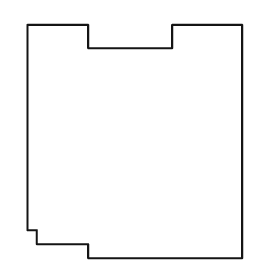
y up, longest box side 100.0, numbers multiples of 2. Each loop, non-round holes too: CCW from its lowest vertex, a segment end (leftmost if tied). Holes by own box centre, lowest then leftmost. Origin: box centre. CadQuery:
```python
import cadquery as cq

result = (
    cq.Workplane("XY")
    .moveTo(-20.0, -50.0)
    .lineTo(46.0, -50.0)
    .lineTo(46.0, 50.0)
    .lineTo(16.0, 50.0)
    .lineTo(16.0, 40.0)
    .lineTo(-20.0, 40.0)
    .lineTo(-20.0, 50.0)
    .lineTo(-46.0, 50.0)
    .lineTo(-46.0, -38.0)
    .lineTo(-42.0, -38.0)
    .lineTo(-42.0, -44.0)
    .lineTo(-20.0, -44.0)
    .close()
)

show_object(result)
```